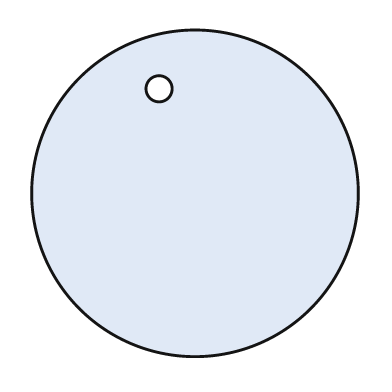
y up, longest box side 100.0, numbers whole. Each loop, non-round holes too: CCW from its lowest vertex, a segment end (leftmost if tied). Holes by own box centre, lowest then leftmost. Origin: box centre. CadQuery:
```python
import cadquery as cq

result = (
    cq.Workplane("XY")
    .moveTo(0.0, 0.0)
    .circle(50.0)
    .moveTo(-11.0, 32.0)
    .circle(4.0)
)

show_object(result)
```